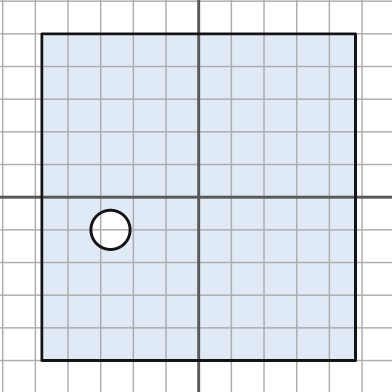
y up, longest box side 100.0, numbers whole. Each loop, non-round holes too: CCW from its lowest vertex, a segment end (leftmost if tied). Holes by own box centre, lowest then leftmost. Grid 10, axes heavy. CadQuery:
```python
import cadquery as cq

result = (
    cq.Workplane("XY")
    .moveTo(-48.0, -50.0)
    .lineTo(48.0, -50.0)
    .lineTo(48.0, 50.0)
    .lineTo(-48.0, 50.0)
    .close()
    .moveTo(-27.0, -10.0)
    .circle(6.0)
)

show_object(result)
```